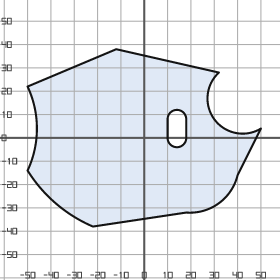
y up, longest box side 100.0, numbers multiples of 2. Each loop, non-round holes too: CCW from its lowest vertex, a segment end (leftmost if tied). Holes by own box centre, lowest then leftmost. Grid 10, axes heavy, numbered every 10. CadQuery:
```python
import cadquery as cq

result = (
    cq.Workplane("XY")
    .moveTo(-22.0, -38.0)
    .lineTo(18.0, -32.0)
    .threePointArc((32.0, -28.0), (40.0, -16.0))
    .lineTo(50.0, 4.0)
    .threePointArc((30.0, 8.0), (32.0, 28.0))
    .lineTo(-12.0, 38.0)
    .lineTo(-50.0, 22.0)
    .threePointArc((-46.0, 4.0), (-50.0, -14.0))
    .threePointArc((-38.0, -28.0), (-22.0, -38.0))
    .close()
    .moveTo(10.0, 0.0)
    .threePointArc((14.0, -4.0), (18.0, 0.0))
    .lineTo(18.0, 8.0)
    .threePointArc((14.0, 12.0), (10.0, 8.0))
    .close()
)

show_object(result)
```